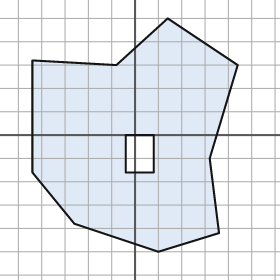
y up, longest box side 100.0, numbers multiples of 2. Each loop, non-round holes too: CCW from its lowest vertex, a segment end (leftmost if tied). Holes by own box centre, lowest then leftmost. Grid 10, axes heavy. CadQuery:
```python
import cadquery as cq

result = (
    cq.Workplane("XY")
    .moveTo(10.0, -50.0)
    .lineTo(36.0, -42.0)
    .lineTo(32.0, -10.0)
    .lineTo(44.0, 30.0)
    .lineTo(14.0, 50.0)
    .lineTo(-8.0, 30.0)
    .lineTo(-44.0, 32.0)
    .lineTo(-44.0, -16.0)
    .lineTo(-26.0, -38.0)
    .close()
    .moveTo(-4.0, -16.0)
    .lineTo(8.0, -16.0)
    .lineTo(8.0, 0.0)
    .lineTo(-4.0, 0.0)
    .close()
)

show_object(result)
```